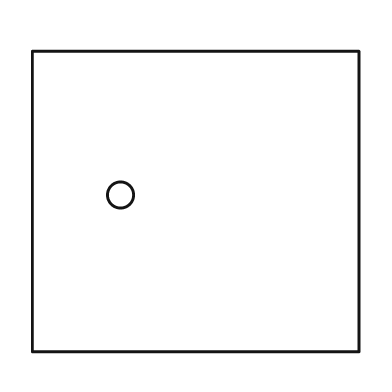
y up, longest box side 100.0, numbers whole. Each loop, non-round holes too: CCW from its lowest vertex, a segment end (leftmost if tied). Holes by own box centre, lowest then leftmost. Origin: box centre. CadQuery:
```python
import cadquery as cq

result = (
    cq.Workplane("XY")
    .moveTo(-50.0, -46.0)
    .lineTo(50.0, -46.0)
    .lineTo(50.0, 46.0)
    .lineTo(-50.0, 46.0)
    .close()
    .moveTo(-23.0, 2.0)
    .circle(4.0)
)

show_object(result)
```